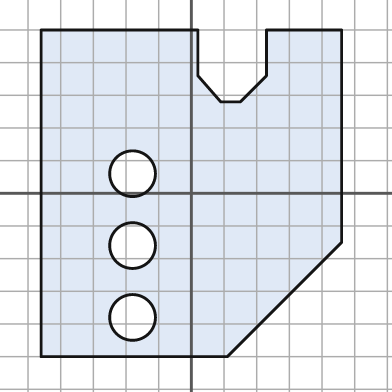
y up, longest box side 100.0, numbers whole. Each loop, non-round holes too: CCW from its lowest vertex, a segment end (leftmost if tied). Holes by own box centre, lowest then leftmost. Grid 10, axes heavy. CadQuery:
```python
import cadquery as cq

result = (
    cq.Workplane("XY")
    .moveTo(-46.0, -50.0)
    .lineTo(11.0, -50.0)
    .lineTo(46.0, -15.0)
    .lineTo(46.0, 50.0)
    .lineTo(23.0, 50.0)
    .lineTo(23.0, 36.0)
    .lineTo(15.0, 28.0)
    .lineTo(9.0, 28.0)
    .lineTo(2.0, 36.0)
    .lineTo(2.0, 50.0)
    .lineTo(-46.0, 50.0)
    .close()
    .moveTo(-18.0, -38.0)
    .circle(7.0)
    .moveTo(-18.0, -16.0)
    .circle(7.0)
    .moveTo(-18.0, 6.0)
    .circle(7.0)
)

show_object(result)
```